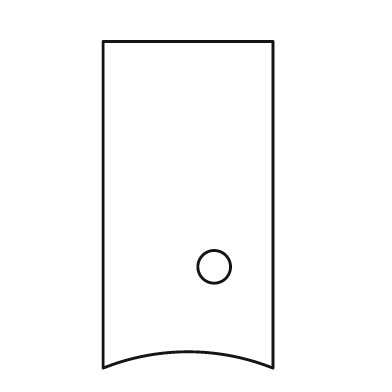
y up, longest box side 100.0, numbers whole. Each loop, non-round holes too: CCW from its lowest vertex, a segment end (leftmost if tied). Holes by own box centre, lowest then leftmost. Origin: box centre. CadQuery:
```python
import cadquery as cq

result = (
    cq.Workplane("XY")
    .moveTo(-26.0, -50.0)
    .threePointArc((0.0, -45.0), (26.0, -50.0))
    .lineTo(26.0, 50.0)
    .lineTo(-26.0, 50.0)
    .close()
    .moveTo(8.0, -19.0)
    .circle(5.0)
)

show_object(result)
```